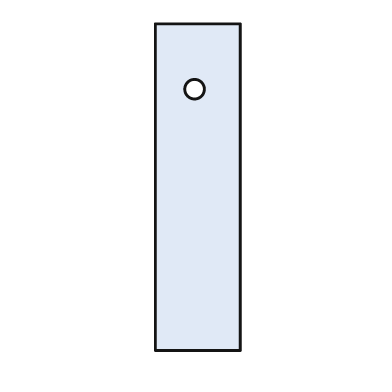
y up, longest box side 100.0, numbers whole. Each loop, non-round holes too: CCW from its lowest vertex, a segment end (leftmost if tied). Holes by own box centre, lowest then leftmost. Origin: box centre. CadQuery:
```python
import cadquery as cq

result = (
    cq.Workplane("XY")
    .moveTo(-13.0, -50.0)
    .lineTo(13.0, -50.0)
    .lineTo(13.0, 50.0)
    .lineTo(-13.0, 50.0)
    .close()
    .moveTo(-1.0, 30.0)
    .circle(3.0)
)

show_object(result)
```